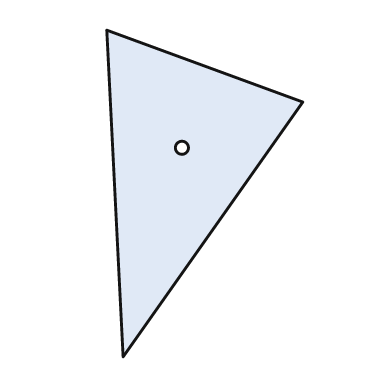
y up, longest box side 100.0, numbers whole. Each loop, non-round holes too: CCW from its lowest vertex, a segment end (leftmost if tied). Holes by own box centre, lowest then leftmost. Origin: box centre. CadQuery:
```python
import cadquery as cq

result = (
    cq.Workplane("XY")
    .moveTo(-25.0, -50.0)
    .lineTo(30.0, 28.0)
    .lineTo(-30.0, 50.0)
    .close()
    .moveTo(-7.0, 14.0)
    .circle(2.0)
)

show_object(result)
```